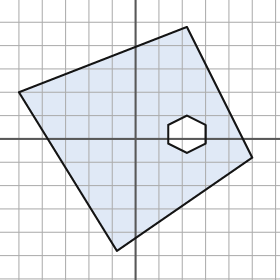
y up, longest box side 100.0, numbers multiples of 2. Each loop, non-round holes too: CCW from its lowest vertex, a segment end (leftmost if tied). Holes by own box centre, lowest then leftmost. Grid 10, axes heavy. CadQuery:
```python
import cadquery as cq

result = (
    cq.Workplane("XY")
    .moveTo(-8.0, -48.0)
    .lineTo(50.0, -8.0)
    .lineTo(22.0, 48.0)
    .lineTo(-50.0, 20.0)
    .close()
    .moveTo(22.0, -6.0)
    .lineTo(30.0, -2.0)
    .lineTo(30.0, 6.0)
    .lineTo(22.0, 10.0)
    .lineTo(14.0, 6.0)
    .lineTo(14.0, -2.0)
    .close()
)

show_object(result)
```